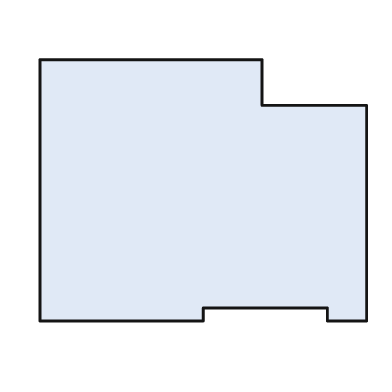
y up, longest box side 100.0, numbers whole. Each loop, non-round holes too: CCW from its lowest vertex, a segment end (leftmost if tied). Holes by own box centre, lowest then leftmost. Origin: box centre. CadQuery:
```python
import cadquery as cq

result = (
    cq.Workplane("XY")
    .moveTo(-50.0, -40.0)
    .lineTo(0.0, -40.0)
    .lineTo(0.0, -36.0)
    .lineTo(38.0, -36.0)
    .lineTo(38.0, -40.0)
    .lineTo(50.0, -40.0)
    .lineTo(50.0, 26.0)
    .lineTo(18.0, 26.0)
    .lineTo(18.0, 40.0)
    .lineTo(-50.0, 40.0)
    .close()
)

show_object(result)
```